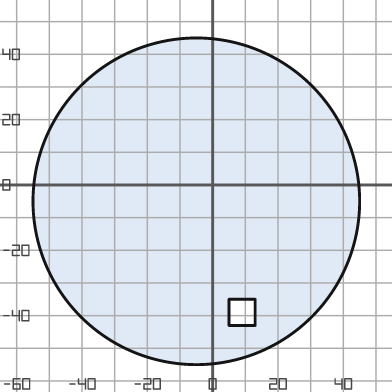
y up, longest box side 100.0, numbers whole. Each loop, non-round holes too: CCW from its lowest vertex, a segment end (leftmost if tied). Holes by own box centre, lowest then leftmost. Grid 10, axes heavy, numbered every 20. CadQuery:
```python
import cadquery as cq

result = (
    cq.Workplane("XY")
    .moveTo(-5.0, -5.0)
    .circle(50.0)
    .moveTo(5.0, -43.0)
    .lineTo(13.0, -43.0)
    .lineTo(13.0, -35.0)
    .lineTo(5.0, -35.0)
    .close()
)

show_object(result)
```